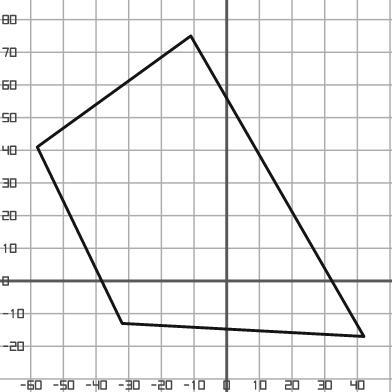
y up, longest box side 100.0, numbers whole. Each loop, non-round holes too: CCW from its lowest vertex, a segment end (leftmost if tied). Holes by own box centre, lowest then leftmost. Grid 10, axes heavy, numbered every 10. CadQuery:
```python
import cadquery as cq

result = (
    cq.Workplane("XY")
    .moveTo(42.0, -17.0)
    .lineTo(-11.0, 75.0)
    .lineTo(-58.0, 41.0)
    .lineTo(-32.0, -13.0)
    .close()
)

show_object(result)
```